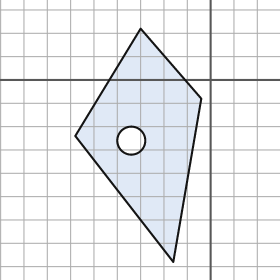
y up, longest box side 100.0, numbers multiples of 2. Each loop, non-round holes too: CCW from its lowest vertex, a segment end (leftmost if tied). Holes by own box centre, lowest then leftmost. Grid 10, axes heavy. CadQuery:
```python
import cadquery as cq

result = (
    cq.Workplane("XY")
    .moveTo(-16.0, -78.0)
    .lineTo(-4.0, -8.0)
    .lineTo(-30.0, 22.0)
    .lineTo(-58.0, -24.0)
    .close()
    .moveTo(-34.0, -26.0)
    .circle(6.0)
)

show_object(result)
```